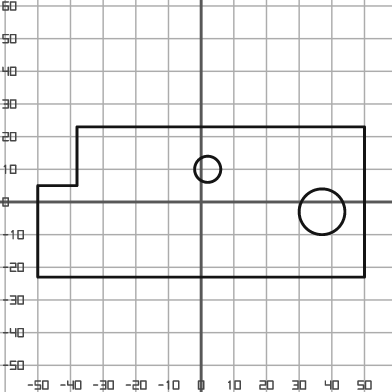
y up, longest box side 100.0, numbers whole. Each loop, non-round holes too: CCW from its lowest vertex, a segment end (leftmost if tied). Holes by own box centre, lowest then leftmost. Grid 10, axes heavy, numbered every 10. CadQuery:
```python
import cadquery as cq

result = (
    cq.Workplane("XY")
    .moveTo(-50.0, -23.0)
    .lineTo(50.0, -23.0)
    .lineTo(50.0, 23.0)
    .lineTo(-38.0, 23.0)
    .lineTo(-38.0, 5.0)
    .lineTo(-50.0, 5.0)
    .close()
    .moveTo(37.0, -3.0)
    .circle(7.0)
    .moveTo(2.0, 10.0)
    .circle(4.0)
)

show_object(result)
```